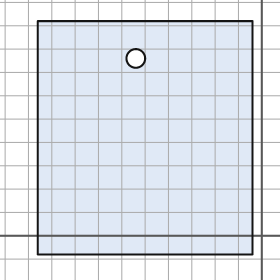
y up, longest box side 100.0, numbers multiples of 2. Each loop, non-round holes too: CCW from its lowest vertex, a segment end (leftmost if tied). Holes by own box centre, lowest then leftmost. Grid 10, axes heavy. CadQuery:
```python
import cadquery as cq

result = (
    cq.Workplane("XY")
    .moveTo(-96.0, -8.0)
    .lineTo(-4.0, -8.0)
    .lineTo(-4.0, 92.0)
    .lineTo(-96.0, 92.0)
    .close()
    .moveTo(-54.0, 76.0)
    .circle(4.0)
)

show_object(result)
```